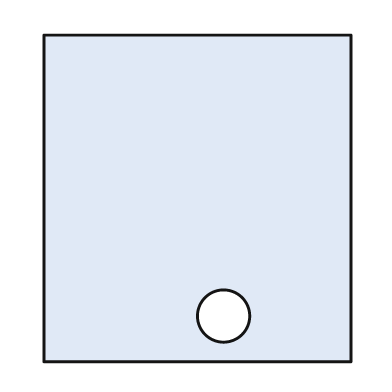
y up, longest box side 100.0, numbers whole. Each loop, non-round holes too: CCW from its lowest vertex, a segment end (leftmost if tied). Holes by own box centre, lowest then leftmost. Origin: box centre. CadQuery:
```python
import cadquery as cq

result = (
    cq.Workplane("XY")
    .moveTo(-47.0, -50.0)
    .lineTo(47.0, -50.0)
    .lineTo(47.0, 50.0)
    .lineTo(-47.0, 50.0)
    .close()
    .moveTo(8.0, -36.0)
    .circle(8.0)
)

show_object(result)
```